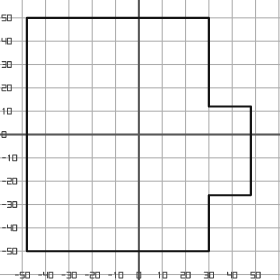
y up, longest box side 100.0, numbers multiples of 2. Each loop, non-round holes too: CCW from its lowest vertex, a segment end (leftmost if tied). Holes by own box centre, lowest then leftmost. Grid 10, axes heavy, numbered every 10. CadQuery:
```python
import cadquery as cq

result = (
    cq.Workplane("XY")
    .moveTo(-48.0, -50.0)
    .lineTo(30.0, -50.0)
    .lineTo(30.0, -26.0)
    .lineTo(48.0, -26.0)
    .lineTo(48.0, 12.0)
    .lineTo(30.0, 12.0)
    .lineTo(30.0, 50.0)
    .lineTo(-48.0, 50.0)
    .close()
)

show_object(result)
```